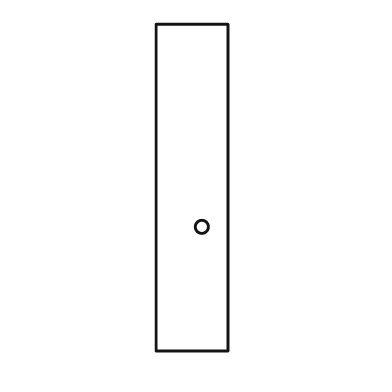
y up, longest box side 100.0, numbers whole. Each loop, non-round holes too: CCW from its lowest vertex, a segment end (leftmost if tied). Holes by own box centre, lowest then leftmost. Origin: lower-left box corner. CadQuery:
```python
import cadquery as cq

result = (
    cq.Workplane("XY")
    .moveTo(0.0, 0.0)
    .lineTo(22.0, 0.0)
    .lineTo(22.0, 100.0)
    .lineTo(0.0, 100.0)
    .close()
    .moveTo(14.0, 38.0)
    .circle(2.0)
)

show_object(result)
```